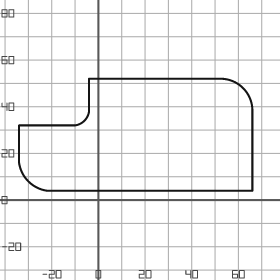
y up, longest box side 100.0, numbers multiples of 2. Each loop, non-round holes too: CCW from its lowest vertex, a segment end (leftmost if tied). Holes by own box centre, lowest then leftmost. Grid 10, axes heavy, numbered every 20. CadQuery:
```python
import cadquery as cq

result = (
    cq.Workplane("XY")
    .moveTo(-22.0, 4.0)
    .lineTo(66.0, 4.0)
    .lineTo(66.0, 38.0)
    .threePointArc((62.0, 48.0), (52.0, 52.0))
    .lineTo(-4.0, 52.0)
    .lineTo(-4.0, 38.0)
    .threePointArc((-6.0, 34.0), (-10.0, 32.0))
    .lineTo(-34.0, 32.0)
    .lineTo(-34.0, 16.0)
    .threePointArc((-30.0, 8.0), (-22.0, 4.0))
    .close()
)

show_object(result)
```